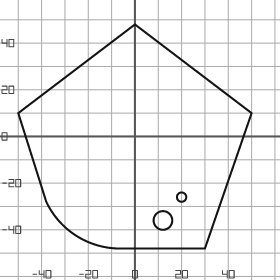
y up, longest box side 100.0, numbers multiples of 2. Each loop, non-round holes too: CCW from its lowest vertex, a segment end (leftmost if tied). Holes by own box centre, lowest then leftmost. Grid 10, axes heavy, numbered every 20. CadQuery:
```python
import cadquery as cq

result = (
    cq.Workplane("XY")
    .moveTo(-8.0, -48.0)
    .lineTo(30.0, -48.0)
    .lineTo(50.0, 10.0)
    .lineTo(0.0, 48.0)
    .lineTo(-50.0, 10.0)
    .lineTo(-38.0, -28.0)
    .threePointArc((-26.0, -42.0), (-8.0, -48.0))
    .close()
    .moveTo(12.0, -36.0)
    .circle(4.0)
    .moveTo(20.0, -26.0)
    .circle(2.0)
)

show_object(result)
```